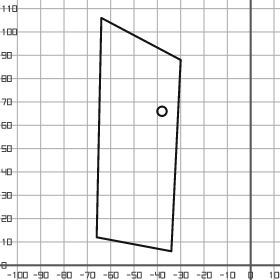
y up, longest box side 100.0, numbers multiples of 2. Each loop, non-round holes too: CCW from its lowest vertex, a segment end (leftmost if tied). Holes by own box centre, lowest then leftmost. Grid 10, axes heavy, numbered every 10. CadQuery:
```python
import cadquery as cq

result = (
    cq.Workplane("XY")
    .moveTo(-34.0, 6.0)
    .lineTo(-30.0, 88.0)
    .lineTo(-64.0, 106.0)
    .lineTo(-66.0, 12.0)
    .close()
    .moveTo(-38.0, 66.0)
    .circle(2.0)
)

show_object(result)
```